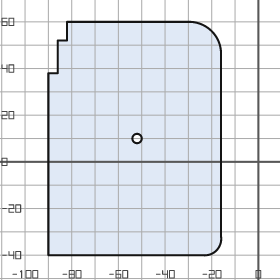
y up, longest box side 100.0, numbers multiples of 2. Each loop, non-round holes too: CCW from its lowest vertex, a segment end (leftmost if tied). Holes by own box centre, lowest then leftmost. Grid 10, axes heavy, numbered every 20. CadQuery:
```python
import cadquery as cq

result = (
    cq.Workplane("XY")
    .moveTo(-90.0, -40.0)
    .lineTo(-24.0, -40.0)
    .threePointArc((-18.0, -38.0), (-16.0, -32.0))
    .lineTo(-16.0, 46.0)
    .threePointArc((-20.0, 56.0), (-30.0, 60.0))
    .lineTo(-82.0, 60.0)
    .lineTo(-82.0, 52.0)
    .lineTo(-86.0, 52.0)
    .lineTo(-86.0, 38.0)
    .lineTo(-90.0, 38.0)
    .close()
    .moveTo(-52.0, 10.0)
    .circle(2.0)
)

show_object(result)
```